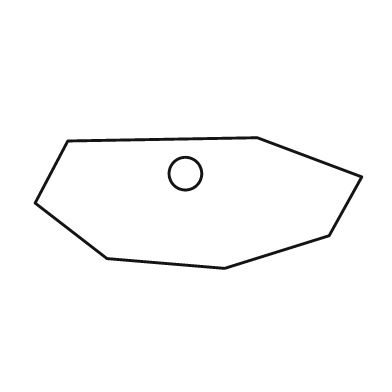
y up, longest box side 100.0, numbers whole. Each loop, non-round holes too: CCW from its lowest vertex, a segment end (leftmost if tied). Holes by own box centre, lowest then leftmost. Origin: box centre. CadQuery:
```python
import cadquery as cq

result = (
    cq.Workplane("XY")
    .moveTo(8.0, -20.0)
    .lineTo(40.0, -10.0)
    .lineTo(50.0, 8.0)
    .lineTo(18.0, 20.0)
    .lineTo(-40.0, 19.0)
    .lineTo(-50.0, 0.0)
    .lineTo(-28.0, -17.0)
    .close()
    .moveTo(-4.0, 9.0)
    .circle(5.0)
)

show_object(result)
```